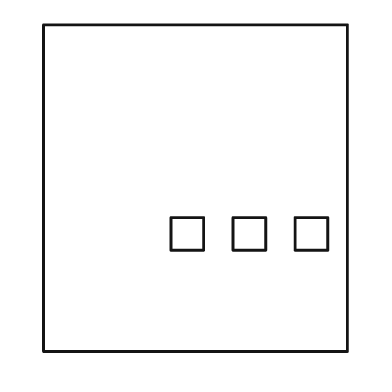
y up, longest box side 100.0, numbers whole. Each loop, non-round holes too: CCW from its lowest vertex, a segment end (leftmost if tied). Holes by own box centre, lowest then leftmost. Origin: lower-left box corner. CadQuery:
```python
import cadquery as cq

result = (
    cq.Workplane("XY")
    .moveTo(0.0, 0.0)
    .lineTo(93.0, 0.0)
    .lineTo(93.0, 100.0)
    .lineTo(0.0, 100.0)
    .close()
    .moveTo(39.0, 31.0)
    .lineTo(49.0, 31.0)
    .lineTo(49.0, 41.0)
    .lineTo(39.0, 41.0)
    .close()
    .moveTo(58.0, 31.0)
    .lineTo(68.0, 31.0)
    .lineTo(68.0, 41.0)
    .lineTo(58.0, 41.0)
    .close()
    .moveTo(77.0, 31.0)
    .lineTo(87.0, 31.0)
    .lineTo(87.0, 41.0)
    .lineTo(77.0, 41.0)
    .close()
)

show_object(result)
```